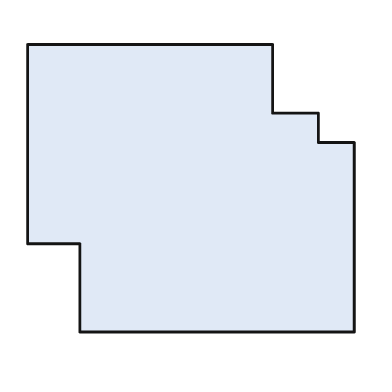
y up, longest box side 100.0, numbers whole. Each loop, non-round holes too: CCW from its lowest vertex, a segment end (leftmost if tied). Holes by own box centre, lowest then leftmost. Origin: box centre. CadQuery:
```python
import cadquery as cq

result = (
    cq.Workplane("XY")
    .moveTo(-34.0, -44.0)
    .lineTo(50.0, -44.0)
    .lineTo(50.0, 14.0)
    .lineTo(39.0, 14.0)
    .lineTo(39.0, 23.0)
    .lineTo(25.0, 23.0)
    .lineTo(25.0, 44.0)
    .lineTo(-50.0, 44.0)
    .lineTo(-50.0, -17.0)
    .lineTo(-34.0, -17.0)
    .close()
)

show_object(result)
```